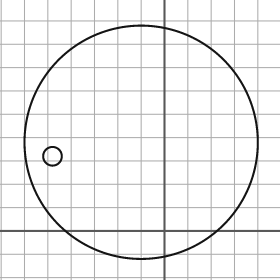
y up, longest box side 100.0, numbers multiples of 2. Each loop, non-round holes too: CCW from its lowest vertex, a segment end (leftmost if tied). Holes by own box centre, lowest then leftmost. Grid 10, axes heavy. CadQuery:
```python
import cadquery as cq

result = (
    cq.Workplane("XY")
    .moveTo(-10.0, 38.0)
    .circle(50.0)
    .moveTo(-48.0, 32.0)
    .circle(4.0)
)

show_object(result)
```